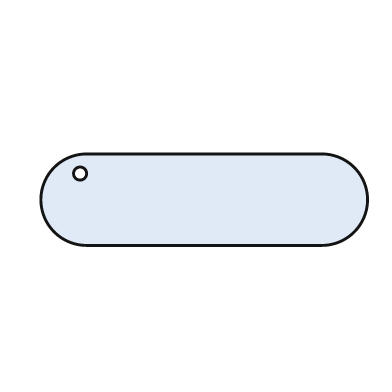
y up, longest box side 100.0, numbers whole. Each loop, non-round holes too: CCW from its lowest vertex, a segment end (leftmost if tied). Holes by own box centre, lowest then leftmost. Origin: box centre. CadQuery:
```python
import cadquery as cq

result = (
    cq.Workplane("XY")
    .moveTo(-36.0, -14.0)
    .lineTo(36.0, -14.0)
    .threePointArc((50.0, 0.0), (36.0, 14.0))
    .lineTo(-36.0, 14.0)
    .threePointArc((-50.0, 0.0), (-36.0, -14.0))
    .close()
    .moveTo(-38.0, 8.0)
    .circle(2.0)
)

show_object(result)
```